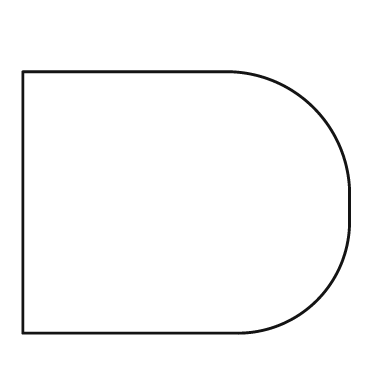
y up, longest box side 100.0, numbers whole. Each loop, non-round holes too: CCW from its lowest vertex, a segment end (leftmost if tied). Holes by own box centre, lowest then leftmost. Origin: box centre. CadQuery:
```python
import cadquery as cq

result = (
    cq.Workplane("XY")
    .moveTo(-50.0, -40.0)
    .lineTo(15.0, -40.0)
    .threePointArc((40.0, -30.0), (50.0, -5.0))
    .lineTo(50.0, 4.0)
    .threePointArc((39.0, 29.0), (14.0, 40.0))
    .lineTo(-50.0, 40.0)
    .close()
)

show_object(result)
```